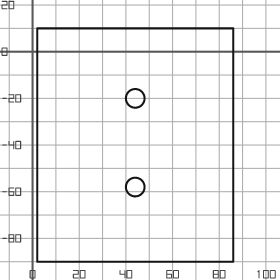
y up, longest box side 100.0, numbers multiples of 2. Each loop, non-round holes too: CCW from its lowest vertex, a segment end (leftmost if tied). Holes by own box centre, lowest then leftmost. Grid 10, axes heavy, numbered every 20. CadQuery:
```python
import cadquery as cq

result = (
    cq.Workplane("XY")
    .moveTo(2.0, -90.0)
    .lineTo(86.0, -90.0)
    .lineTo(86.0, 10.0)
    .lineTo(2.0, 10.0)
    .close()
    .moveTo(44.0, -58.0)
    .circle(4.0)
    .moveTo(44.0, -20.0)
    .circle(4.0)
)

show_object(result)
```